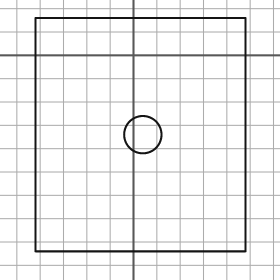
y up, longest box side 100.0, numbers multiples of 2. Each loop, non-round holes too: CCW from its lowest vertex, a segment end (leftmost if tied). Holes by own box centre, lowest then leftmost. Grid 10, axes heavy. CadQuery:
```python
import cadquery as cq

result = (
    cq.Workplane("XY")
    .moveTo(-42.0, -84.0)
    .lineTo(48.0, -84.0)
    .lineTo(48.0, 16.0)
    .lineTo(-42.0, 16.0)
    .close()
    .moveTo(4.0, -34.0)
    .circle(8.0)
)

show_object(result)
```